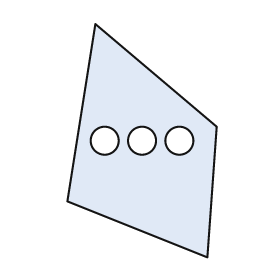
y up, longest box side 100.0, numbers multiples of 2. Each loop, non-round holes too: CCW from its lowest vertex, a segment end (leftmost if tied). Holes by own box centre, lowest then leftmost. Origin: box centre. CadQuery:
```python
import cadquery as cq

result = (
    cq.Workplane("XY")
    .moveTo(28.0, -50.0)
    .lineTo(32.0, 6.0)
    .lineTo(-20.0, 50.0)
    .lineTo(-32.0, -26.0)
    .close()
    .moveTo(-16.0, 0.0)
    .circle(6.0)
    .moveTo(0.0, 0.0)
    .circle(6.0)
    .moveTo(16.0, 0.0)
    .circle(6.0)
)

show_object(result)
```